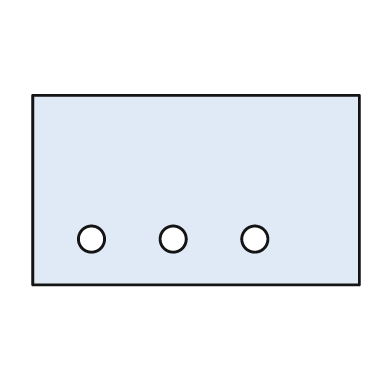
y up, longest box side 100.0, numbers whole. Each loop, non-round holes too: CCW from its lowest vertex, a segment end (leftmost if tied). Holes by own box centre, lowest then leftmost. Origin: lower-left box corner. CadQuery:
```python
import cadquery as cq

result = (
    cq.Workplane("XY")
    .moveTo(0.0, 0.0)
    .lineTo(100.0, 0.0)
    .lineTo(100.0, 58.0)
    .lineTo(0.0, 58.0)
    .close()
    .moveTo(18.0, 14.0)
    .circle(4.0)
    .moveTo(43.0, 14.0)
    .circle(4.0)
    .moveTo(68.0, 14.0)
    .circle(4.0)
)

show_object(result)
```